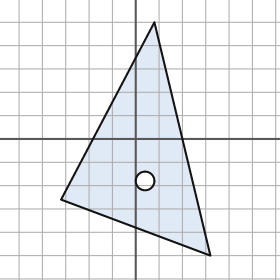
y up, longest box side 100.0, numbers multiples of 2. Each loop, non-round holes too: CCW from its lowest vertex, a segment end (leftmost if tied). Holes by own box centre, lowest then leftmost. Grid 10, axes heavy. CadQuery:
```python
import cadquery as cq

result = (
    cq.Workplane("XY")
    .moveTo(32.0, -50.0)
    .lineTo(8.0, 50.0)
    .lineTo(-32.0, -26.0)
    .close()
    .moveTo(4.0, -18.0)
    .circle(4.0)
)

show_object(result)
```